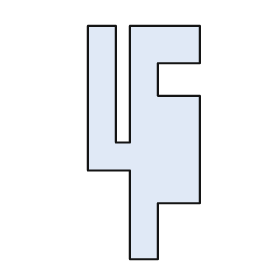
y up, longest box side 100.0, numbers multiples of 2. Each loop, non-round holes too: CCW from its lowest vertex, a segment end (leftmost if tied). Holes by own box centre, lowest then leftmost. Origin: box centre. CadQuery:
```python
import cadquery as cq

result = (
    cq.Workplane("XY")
    .moveTo(-6.0, -50.0)
    .lineTo(6.0, -50.0)
    .lineTo(6.0, -26.0)
    .lineTo(24.0, -26.0)
    .lineTo(24.0, 20.0)
    .lineTo(6.0, 20.0)
    .lineTo(6.0, 34.0)
    .lineTo(24.0, 34.0)
    .lineTo(24.0, 50.0)
    .lineTo(-6.0, 50.0)
    .lineTo(-6.0, 0.0)
    .lineTo(-12.0, 0.0)
    .lineTo(-12.0, 50.0)
    .lineTo(-24.0, 50.0)
    .lineTo(-24.0, -12.0)
    .lineTo(-6.0, -12.0)
    .close()
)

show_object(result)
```